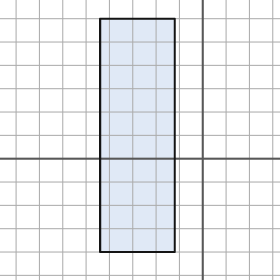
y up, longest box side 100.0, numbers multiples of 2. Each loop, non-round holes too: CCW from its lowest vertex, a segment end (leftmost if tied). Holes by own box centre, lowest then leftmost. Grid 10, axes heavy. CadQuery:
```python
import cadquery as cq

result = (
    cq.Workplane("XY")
    .moveTo(-44.0, -40.0)
    .lineTo(-12.0, -40.0)
    .lineTo(-12.0, 60.0)
    .lineTo(-44.0, 60.0)
    .close()
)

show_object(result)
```